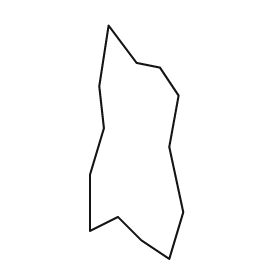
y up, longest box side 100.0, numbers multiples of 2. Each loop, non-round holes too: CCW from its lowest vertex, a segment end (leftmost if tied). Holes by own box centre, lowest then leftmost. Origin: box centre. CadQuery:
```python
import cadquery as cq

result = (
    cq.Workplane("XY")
    .moveTo(14.0, -50.0)
    .lineTo(20.0, -30.0)
    .lineTo(14.0, -2.0)
    .lineTo(18.0, 20.0)
    .lineTo(10.0, 32.0)
    .lineTo(0.0, 34.0)
    .lineTo(-12.0, 50.0)
    .lineTo(-16.0, 24.0)
    .lineTo(-14.0, 6.0)
    .lineTo(-20.0, -14.0)
    .lineTo(-20.0, -38.0)
    .lineTo(-8.0, -32.0)
    .lineTo(2.0, -42.0)
    .close()
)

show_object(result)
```